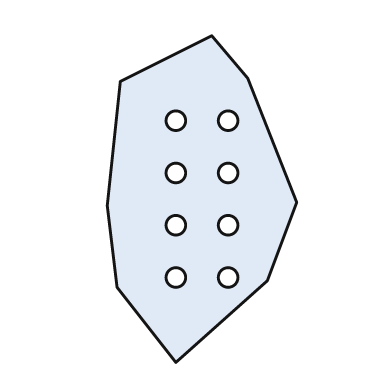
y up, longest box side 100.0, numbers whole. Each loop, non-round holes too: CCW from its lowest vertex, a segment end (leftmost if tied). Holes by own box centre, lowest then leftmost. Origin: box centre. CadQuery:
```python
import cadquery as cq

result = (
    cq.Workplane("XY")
    .moveTo(-8.0, -50.0)
    .lineTo(20.0, -25.0)
    .lineTo(29.0, -1.0)
    .lineTo(14.0, 37.0)
    .lineTo(3.0, 50.0)
    .lineTo(-25.0, 36.0)
    .lineTo(-29.0, -2.0)
    .lineTo(-26.0, -27.0)
    .close()
    .moveTo(-8.0, -24.0)
    .circle(3.0)
    .moveTo(8.0, -24.0)
    .circle(3.0)
    .moveTo(-8.0, -8.0)
    .circle(3.0)
    .moveTo(8.0, -8.0)
    .circle(3.0)
    .moveTo(-8.0, 8.0)
    .circle(3.0)
    .moveTo(8.0, 8.0)
    .circle(3.0)
    .moveTo(-8.0, 24.0)
    .circle(3.0)
    .moveTo(8.0, 24.0)
    .circle(3.0)
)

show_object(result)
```